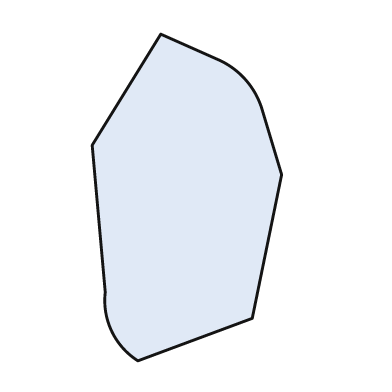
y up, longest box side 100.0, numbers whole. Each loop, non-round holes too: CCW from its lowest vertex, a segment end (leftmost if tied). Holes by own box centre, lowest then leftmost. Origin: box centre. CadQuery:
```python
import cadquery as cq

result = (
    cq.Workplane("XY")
    .moveTo(-15.0, -50.0)
    .lineTo(20.0, -37.0)
    .lineTo(29.0, 7.0)
    .lineTo(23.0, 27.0)
    .threePointArc((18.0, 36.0), (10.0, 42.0))
    .lineTo(-8.0, 50.0)
    .lineTo(-29.0, 16.0)
    .lineTo(-25.0, -29.0)
    .threePointArc((-23.0, -41.0), (-15.0, -50.0))
    .close()
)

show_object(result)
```